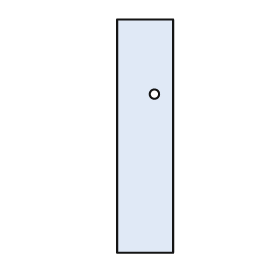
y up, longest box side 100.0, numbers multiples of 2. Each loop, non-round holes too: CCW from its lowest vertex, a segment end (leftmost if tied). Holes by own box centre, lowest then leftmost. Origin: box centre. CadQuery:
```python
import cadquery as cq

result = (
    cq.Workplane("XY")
    .moveTo(-12.0, -50.0)
    .lineTo(12.0, -50.0)
    .lineTo(12.0, 50.0)
    .lineTo(-12.0, 50.0)
    .close()
    .moveTo(4.0, 18.0)
    .circle(2.0)
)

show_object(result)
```